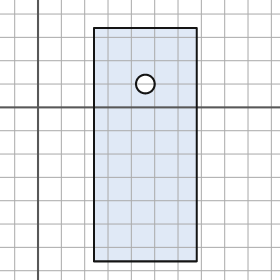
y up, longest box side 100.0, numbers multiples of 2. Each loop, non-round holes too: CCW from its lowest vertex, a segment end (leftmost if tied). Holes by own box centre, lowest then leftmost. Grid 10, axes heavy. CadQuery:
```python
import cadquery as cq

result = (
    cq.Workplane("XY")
    .moveTo(24.0, -66.0)
    .lineTo(68.0, -66.0)
    .lineTo(68.0, 34.0)
    .lineTo(24.0, 34.0)
    .close()
    .moveTo(46.0, 10.0)
    .circle(4.0)
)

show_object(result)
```